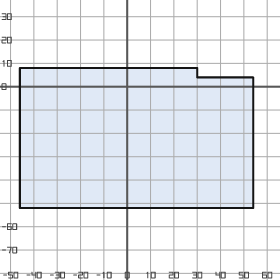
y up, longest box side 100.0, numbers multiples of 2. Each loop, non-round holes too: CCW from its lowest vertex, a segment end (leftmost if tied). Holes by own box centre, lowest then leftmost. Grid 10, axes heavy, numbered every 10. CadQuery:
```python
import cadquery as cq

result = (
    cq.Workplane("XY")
    .moveTo(-46.0, -52.0)
    .lineTo(54.0, -52.0)
    .lineTo(54.0, 4.0)
    .lineTo(30.0, 4.0)
    .lineTo(30.0, 8.0)
    .lineTo(-46.0, 8.0)
    .close()
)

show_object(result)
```